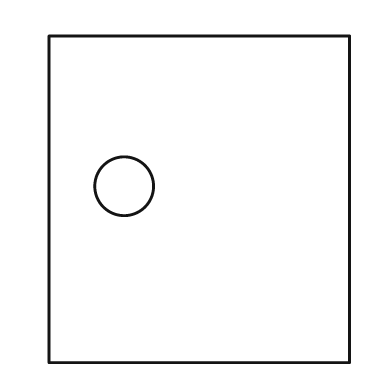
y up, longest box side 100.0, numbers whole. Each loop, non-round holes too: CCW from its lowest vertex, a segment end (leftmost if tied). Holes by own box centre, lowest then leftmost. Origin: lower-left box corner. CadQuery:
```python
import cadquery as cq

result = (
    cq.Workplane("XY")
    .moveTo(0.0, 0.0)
    .lineTo(92.0, 0.0)
    .lineTo(92.0, 100.0)
    .lineTo(0.0, 100.0)
    .close()
    .moveTo(23.0, 54.0)
    .circle(9.0)
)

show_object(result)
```